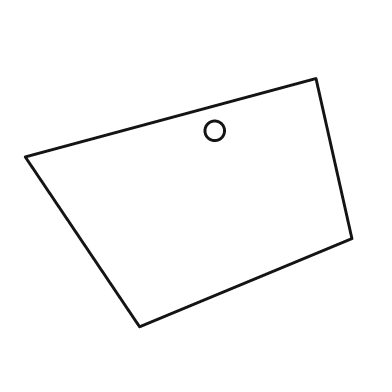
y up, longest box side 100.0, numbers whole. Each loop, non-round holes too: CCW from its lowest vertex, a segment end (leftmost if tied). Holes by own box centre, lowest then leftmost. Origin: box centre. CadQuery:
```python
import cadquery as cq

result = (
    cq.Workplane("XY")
    .moveTo(-15.0, -38.0)
    .lineTo(50.0, -11.0)
    .lineTo(39.0, 38.0)
    .lineTo(-50.0, 14.0)
    .close()
    .moveTo(8.0, 22.0)
    .circle(3.0)
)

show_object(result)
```